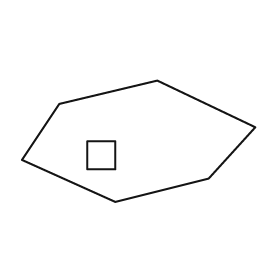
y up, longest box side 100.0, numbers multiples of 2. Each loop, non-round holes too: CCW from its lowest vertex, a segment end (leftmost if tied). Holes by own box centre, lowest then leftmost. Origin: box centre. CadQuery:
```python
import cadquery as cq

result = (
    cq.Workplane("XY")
    .moveTo(-10.0, -26.0)
    .lineTo(30.0, -16.0)
    .lineTo(50.0, 6.0)
    .lineTo(8.0, 26.0)
    .lineTo(-34.0, 16.0)
    .lineTo(-50.0, -8.0)
    .close()
    .moveTo(-22.0, -12.0)
    .lineTo(-10.0, -12.0)
    .lineTo(-10.0, 0.0)
    .lineTo(-22.0, 0.0)
    .close()
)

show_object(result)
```